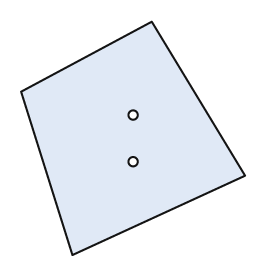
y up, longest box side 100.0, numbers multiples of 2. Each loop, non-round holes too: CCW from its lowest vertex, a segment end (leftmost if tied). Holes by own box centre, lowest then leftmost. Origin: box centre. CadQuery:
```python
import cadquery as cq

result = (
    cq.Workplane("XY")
    .moveTo(-26.0, -50.0)
    .lineTo(48.0, -16.0)
    .lineTo(8.0, 50.0)
    .lineTo(-48.0, 20.0)
    .close()
    .moveTo(0.0, -10.0)
    .circle(2.0)
    .moveTo(0.0, 10.0)
    .circle(2.0)
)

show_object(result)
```